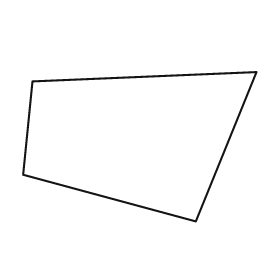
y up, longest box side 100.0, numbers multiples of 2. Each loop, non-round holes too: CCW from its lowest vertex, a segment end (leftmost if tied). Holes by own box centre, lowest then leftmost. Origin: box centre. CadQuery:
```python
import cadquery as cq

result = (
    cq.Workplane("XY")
    .moveTo(24.0, -32.0)
    .lineTo(50.0, 32.0)
    .lineTo(-46.0, 28.0)
    .lineTo(-50.0, -12.0)
    .close()
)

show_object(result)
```